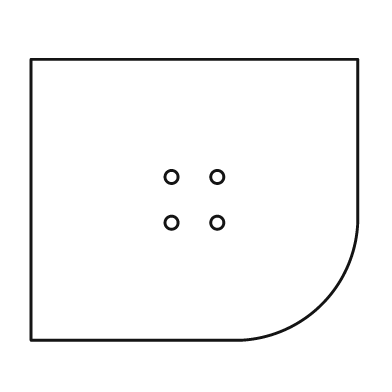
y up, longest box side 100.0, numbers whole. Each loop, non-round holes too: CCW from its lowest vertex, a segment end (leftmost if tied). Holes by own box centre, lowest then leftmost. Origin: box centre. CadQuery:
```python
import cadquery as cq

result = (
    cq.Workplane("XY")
    .moveTo(-50.0, -43.0)
    .lineTo(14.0, -43.0)
    .threePointArc((39.0, -32.0), (50.0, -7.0))
    .lineTo(50.0, 43.0)
    .lineTo(-50.0, 43.0)
    .close()
    .moveTo(-7.0, -7.0)
    .circle(2.0)
    .moveTo(7.0, -7.0)
    .circle(2.0)
    .moveTo(-7.0, 7.0)
    .circle(2.0)
    .moveTo(7.0, 7.0)
    .circle(2.0)
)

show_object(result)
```